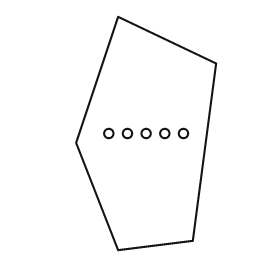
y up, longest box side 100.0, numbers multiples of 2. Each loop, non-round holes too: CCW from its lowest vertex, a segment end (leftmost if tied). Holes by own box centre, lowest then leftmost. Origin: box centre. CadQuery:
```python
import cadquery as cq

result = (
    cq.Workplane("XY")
    .moveTo(-12.0, -50.0)
    .lineTo(20.0, -46.0)
    .lineTo(30.0, 30.0)
    .lineTo(-12.0, 50.0)
    .lineTo(-30.0, -4.0)
    .close()
    .moveTo(-16.0, 0.0)
    .circle(2.0)
    .moveTo(-8.0, 0.0)
    .circle(2.0)
    .moveTo(0.0, 0.0)
    .circle(2.0)
    .moveTo(8.0, 0.0)
    .circle(2.0)
    .moveTo(16.0, 0.0)
    .circle(2.0)
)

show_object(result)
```